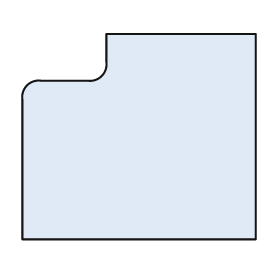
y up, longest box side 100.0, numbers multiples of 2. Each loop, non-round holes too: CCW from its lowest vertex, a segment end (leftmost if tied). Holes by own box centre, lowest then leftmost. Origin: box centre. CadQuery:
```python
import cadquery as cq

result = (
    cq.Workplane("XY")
    .moveTo(-50.0, -44.0)
    .lineTo(50.0, -44.0)
    .lineTo(50.0, 44.0)
    .lineTo(-14.0, 44.0)
    .lineTo(-14.0, 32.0)
    .threePointArc((-16.0, 26.0), (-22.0, 24.0))
    .lineTo(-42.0, 24.0)
    .threePointArc((-48.0, 22.0), (-50.0, 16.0))
    .close()
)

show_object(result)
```